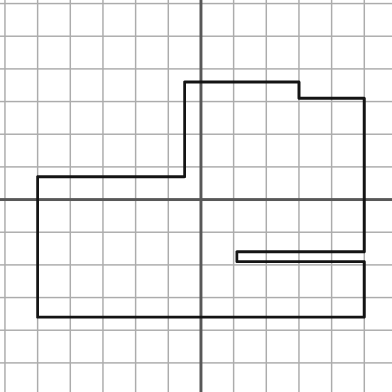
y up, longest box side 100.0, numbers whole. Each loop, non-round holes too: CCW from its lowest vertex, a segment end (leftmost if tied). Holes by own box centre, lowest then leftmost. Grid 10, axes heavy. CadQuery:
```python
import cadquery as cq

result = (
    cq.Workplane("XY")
    .moveTo(-50.0, -36.0)
    .lineTo(50.0, -36.0)
    .lineTo(50.0, -19.0)
    .lineTo(11.0, -19.0)
    .lineTo(11.0, -16.0)
    .lineTo(50.0, -16.0)
    .lineTo(50.0, 31.0)
    .lineTo(30.0, 31.0)
    .lineTo(30.0, 36.0)
    .lineTo(-5.0, 36.0)
    .lineTo(-5.0, 7.0)
    .lineTo(-50.0, 7.0)
    .close()
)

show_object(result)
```